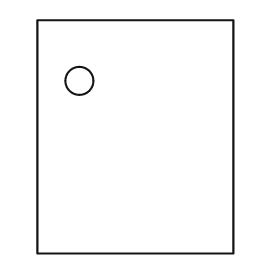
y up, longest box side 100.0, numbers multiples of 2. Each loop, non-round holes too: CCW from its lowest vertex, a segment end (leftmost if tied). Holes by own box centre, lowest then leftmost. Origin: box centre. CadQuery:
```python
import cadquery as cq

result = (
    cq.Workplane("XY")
    .moveTo(-42.0, -50.0)
    .lineTo(42.0, -50.0)
    .lineTo(42.0, 50.0)
    .lineTo(-42.0, 50.0)
    .close()
    .moveTo(-24.0, 24.0)
    .circle(6.0)
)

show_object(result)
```